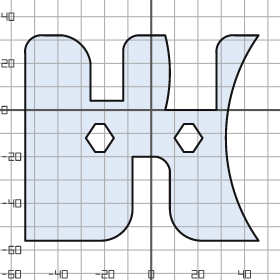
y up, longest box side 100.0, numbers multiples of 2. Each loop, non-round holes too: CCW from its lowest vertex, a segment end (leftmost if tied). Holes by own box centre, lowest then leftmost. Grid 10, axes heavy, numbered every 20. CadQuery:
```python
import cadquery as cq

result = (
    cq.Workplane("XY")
    .moveTo(-54.0, -56.0)
    .lineTo(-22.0, -56.0)
    .threePointArc((-12.0, -52.0), (-8.0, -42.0))
    .lineTo(-8.0, -20.0)
    .lineTo(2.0, -20.0)
    .threePointArc((6.0, -22.0), (8.0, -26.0))
    .lineTo(8.0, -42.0)
    .threePointArc((12.0, -52.0), (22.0, -56.0))
    .lineTo(46.0, -56.0)
    .threePointArc((32.0, -12.0), (46.0, 32.0))
    .lineTo(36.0, 32.0)
    .threePointArc((30.0, 30.0), (28.0, 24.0))
    .lineTo(28.0, 0.0)
    .lineTo(6.0, 0.0)
    .threePointArc((8.0, 16.0), (6.0, 32.0))
    .lineTo(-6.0, 32.0)
    .threePointArc((-10.0, 30.0), (-12.0, 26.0))
    .lineTo(-12.0, 4.0)
    .lineTo(-26.0, 4.0)
    .lineTo(-26.0, 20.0)
    .threePointArc((-30.0, 28.0), (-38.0, 32.0))
    .lineTo(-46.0, 32.0)
    .threePointArc((-52.0, 30.0), (-54.0, 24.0))
    .close()
    .moveTo(-24.0, -18.0)
    .lineTo(-20.0, -18.0)
    .lineTo(-16.0, -12.0)
    .lineTo(-20.0, -6.0)
    .lineTo(-24.0, -6.0)
    .lineTo(-28.0, -12.0)
    .close()
    .moveTo(14.0, -18.0)
    .lineTo(18.0, -18.0)
    .lineTo(22.0, -12.0)
    .lineTo(18.0, -6.0)
    .lineTo(14.0, -6.0)
    .lineTo(10.0, -12.0)
    .close()
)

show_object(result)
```